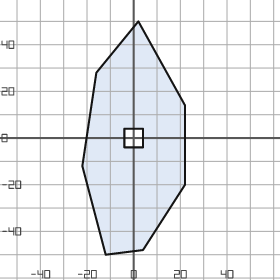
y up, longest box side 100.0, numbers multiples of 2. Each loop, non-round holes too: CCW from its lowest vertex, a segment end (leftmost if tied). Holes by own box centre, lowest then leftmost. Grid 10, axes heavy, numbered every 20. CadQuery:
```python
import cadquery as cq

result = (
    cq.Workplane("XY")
    .moveTo(-12.0, -50.0)
    .lineTo(4.0, -48.0)
    .lineTo(22.0, -20.0)
    .lineTo(22.0, 14.0)
    .lineTo(2.0, 50.0)
    .lineTo(-16.0, 28.0)
    .lineTo(-22.0, -12.0)
    .close()
    .moveTo(-4.0, -4.0)
    .lineTo(4.0, -4.0)
    .lineTo(4.0, 4.0)
    .lineTo(-4.0, 4.0)
    .close()
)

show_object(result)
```